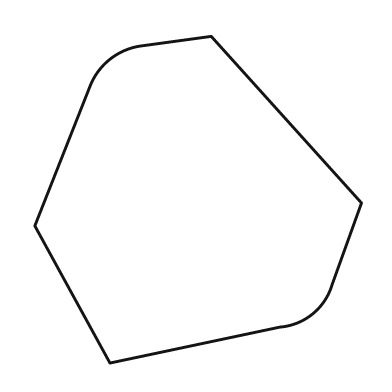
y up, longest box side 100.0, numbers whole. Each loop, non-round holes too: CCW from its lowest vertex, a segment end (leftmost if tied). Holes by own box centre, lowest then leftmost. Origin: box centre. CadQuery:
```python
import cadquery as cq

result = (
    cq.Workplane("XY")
    .moveTo(-27.0, -50.0)
    .lineTo(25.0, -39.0)
    .threePointArc((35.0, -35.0), (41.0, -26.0))
    .lineTo(50.0, -1.0)
    .lineTo(4.0, 50.0)
    .lineTo(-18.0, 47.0)
    .threePointArc((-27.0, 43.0), (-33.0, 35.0))
    .lineTo(-50.0, -8.0)
    .close()
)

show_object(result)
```